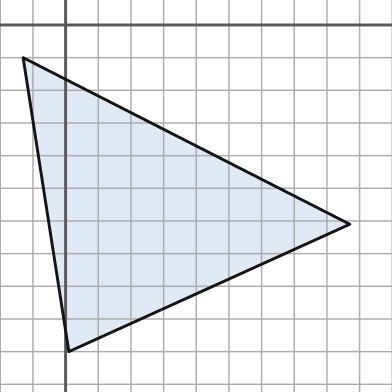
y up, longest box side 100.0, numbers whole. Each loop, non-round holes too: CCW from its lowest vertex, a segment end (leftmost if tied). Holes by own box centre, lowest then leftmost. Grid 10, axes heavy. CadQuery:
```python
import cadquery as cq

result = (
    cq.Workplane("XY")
    .moveTo(1.0, -100.0)
    .lineTo(87.0, -61.0)
    .lineTo(-13.0, -10.0)
    .close()
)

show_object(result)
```